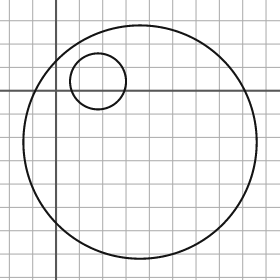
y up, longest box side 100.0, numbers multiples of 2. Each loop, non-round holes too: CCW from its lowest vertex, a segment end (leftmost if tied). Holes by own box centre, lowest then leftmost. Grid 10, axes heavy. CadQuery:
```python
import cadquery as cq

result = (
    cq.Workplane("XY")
    .moveTo(36.0, -22.0)
    .circle(50.0)
    .moveTo(18.0, 4.0)
    .circle(12.0)
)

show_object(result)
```